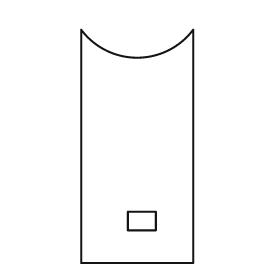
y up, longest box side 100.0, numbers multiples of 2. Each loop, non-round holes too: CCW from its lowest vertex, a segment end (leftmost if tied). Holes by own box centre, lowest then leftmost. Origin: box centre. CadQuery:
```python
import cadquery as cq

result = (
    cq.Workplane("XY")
    .moveTo(-24.0, -50.0)
    .lineTo(24.0, -50.0)
    .lineTo(24.0, 50.0)
    .threePointArc((0.0, 38.0), (-24.0, 50.0))
    .close()
    .moveTo(-4.0, -36.0)
    .lineTo(8.0, -36.0)
    .lineTo(8.0, -28.0)
    .lineTo(-4.0, -28.0)
    .close()
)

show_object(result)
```